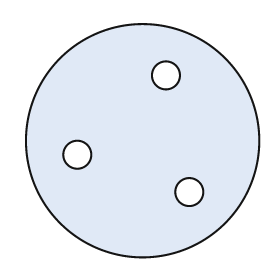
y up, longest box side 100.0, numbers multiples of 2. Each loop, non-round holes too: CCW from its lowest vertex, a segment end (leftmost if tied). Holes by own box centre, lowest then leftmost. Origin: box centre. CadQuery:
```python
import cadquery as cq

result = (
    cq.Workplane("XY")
    .moveTo(0.0, 0.0)
    .circle(50.0)
    .moveTo(20.0, -22.0)
    .circle(6.0)
    .moveTo(-28.0, -6.0)
    .circle(6.0)
    .moveTo(10.0, 28.0)
    .circle(6.0)
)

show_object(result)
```